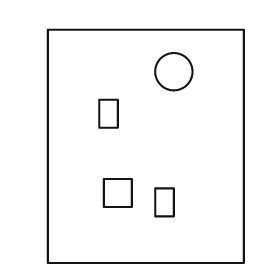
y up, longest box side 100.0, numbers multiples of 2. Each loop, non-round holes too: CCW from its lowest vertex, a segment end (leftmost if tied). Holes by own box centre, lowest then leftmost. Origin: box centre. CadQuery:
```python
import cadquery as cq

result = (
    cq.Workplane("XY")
    .moveTo(-42.0, -50.0)
    .lineTo(42.0, -50.0)
    .lineTo(42.0, 50.0)
    .lineTo(-42.0, 50.0)
    .close()
    .moveTo(4.0, -30.0)
    .lineTo(12.0, -30.0)
    .lineTo(12.0, -18.0)
    .lineTo(4.0, -18.0)
    .close()
    .moveTo(-18.0, -26.0)
    .lineTo(-6.0, -26.0)
    .lineTo(-6.0, -14.0)
    .lineTo(-18.0, -14.0)
    .close()
    .moveTo(-20.0, 8.0)
    .lineTo(-12.0, 8.0)
    .lineTo(-12.0, 20.0)
    .lineTo(-20.0, 20.0)
    .close()
    .moveTo(12.0, 32.0)
    .circle(8.0)
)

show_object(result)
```